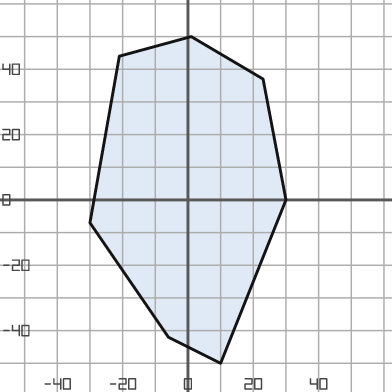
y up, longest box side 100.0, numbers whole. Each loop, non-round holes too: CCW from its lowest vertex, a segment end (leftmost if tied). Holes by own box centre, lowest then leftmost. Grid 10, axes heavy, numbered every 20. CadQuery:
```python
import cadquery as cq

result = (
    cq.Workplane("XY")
    .moveTo(10.0, -50.0)
    .lineTo(30.0, 0.0)
    .lineTo(23.0, 37.0)
    .lineTo(1.0, 50.0)
    .lineTo(-21.0, 44.0)
    .lineTo(-30.0, -7.0)
    .lineTo(-6.0, -42.0)
    .close()
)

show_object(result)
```